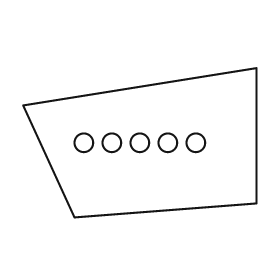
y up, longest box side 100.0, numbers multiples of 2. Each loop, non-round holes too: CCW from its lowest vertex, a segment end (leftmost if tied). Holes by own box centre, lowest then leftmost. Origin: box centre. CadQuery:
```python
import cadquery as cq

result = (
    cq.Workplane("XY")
    .moveTo(-28.0, -32.0)
    .lineTo(50.0, -26.0)
    .lineTo(50.0, 32.0)
    .lineTo(-50.0, 16.0)
    .close()
    .moveTo(-24.0, 0.0)
    .circle(4.0)
    .moveTo(-12.0, 0.0)
    .circle(4.0)
    .moveTo(0.0, 0.0)
    .circle(4.0)
    .moveTo(12.0, 0.0)
    .circle(4.0)
    .moveTo(24.0, 0.0)
    .circle(4.0)
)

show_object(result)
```